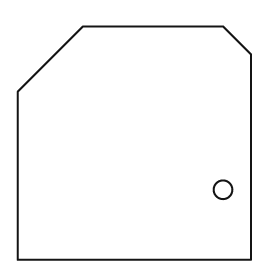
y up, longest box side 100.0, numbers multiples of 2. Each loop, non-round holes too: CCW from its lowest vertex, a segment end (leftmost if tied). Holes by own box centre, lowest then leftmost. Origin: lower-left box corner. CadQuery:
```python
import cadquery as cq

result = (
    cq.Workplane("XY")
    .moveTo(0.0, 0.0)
    .lineTo(100.0, 0.0)
    .lineTo(100.0, 88.0)
    .lineTo(88.0, 100.0)
    .lineTo(28.0, 100.0)
    .lineTo(0.0, 72.0)
    .close()
    .moveTo(88.0, 30.0)
    .circle(4.0)
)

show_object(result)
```